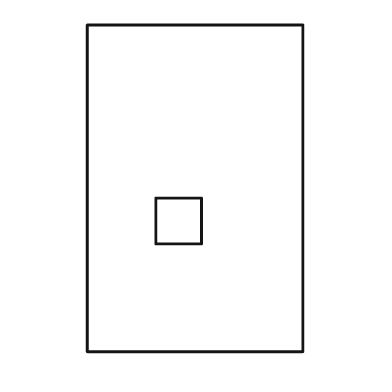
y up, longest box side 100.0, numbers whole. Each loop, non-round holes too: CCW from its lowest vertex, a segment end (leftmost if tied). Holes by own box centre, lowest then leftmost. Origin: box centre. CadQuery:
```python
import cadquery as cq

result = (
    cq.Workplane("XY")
    .moveTo(-33.0, -50.0)
    .lineTo(33.0, -50.0)
    .lineTo(33.0, 50.0)
    .lineTo(-33.0, 50.0)
    .close()
    .moveTo(-12.0, -17.0)
    .lineTo(2.0, -17.0)
    .lineTo(2.0, -3.0)
    .lineTo(-12.0, -3.0)
    .close()
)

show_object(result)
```